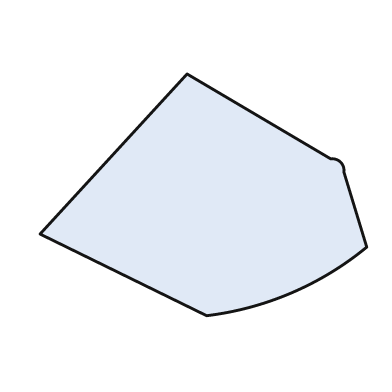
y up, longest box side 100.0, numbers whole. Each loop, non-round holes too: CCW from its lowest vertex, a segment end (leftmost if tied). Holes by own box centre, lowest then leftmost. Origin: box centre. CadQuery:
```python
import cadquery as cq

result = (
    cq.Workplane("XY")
    .moveTo(1.0, -37.0)
    .threePointArc((27.0, -30.0), (50.0, -16.0))
    .lineTo(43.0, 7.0)
    .threePointArc((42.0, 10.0), (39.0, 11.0))
    .lineTo(-5.0, 37.0)
    .lineTo(-50.0, -12.0)
    .close()
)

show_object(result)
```